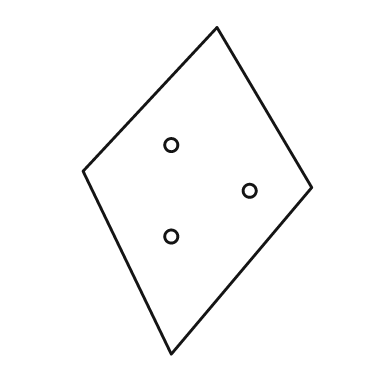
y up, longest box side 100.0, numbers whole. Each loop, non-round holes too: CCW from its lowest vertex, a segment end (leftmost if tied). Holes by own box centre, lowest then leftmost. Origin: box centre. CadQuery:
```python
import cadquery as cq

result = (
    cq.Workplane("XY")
    .moveTo(-8.0, -50.0)
    .lineTo(35.0, 1.0)
    .lineTo(6.0, 50.0)
    .lineTo(-35.0, 6.0)
    .close()
    .moveTo(-8.0, -14.0)
    .circle(2.0)
    .moveTo(16.0, 0.0)
    .circle(2.0)
    .moveTo(-8.0, 14.0)
    .circle(2.0)
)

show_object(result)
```